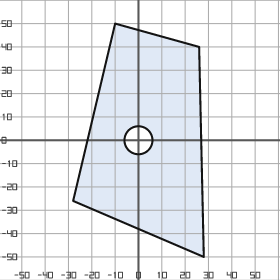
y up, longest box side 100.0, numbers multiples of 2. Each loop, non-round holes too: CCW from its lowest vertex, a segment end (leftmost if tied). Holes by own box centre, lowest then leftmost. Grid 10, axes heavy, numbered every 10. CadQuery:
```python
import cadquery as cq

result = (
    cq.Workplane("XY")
    .moveTo(28.0, -50.0)
    .lineTo(26.0, 40.0)
    .lineTo(-10.0, 50.0)
    .lineTo(-28.0, -26.0)
    .close()
    .moveTo(0.0, 0.0)
    .circle(6.0)
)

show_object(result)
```